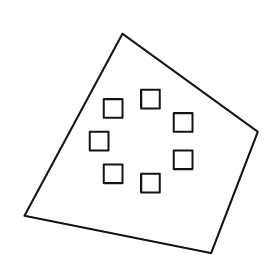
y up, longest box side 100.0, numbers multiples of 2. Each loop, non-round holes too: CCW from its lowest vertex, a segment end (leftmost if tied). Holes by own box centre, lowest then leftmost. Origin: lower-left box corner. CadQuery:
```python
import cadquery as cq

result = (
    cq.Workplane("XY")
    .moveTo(80.0, 0.0)
    .lineTo(100.0, 52.0)
    .lineTo(42.0, 94.0)
    .lineTo(0.0, 16.0)
    .close()
    .moveTo(50.0, 26.0)
    .lineTo(58.0, 26.0)
    .lineTo(58.0, 34.0)
    .lineTo(50.0, 34.0)
    .close()
    .moveTo(34.0, 30.0)
    .lineTo(42.0, 30.0)
    .lineTo(42.0, 38.0)
    .lineTo(34.0, 38.0)
    .close()
    .moveTo(64.0, 36.0)
    .lineTo(72.0, 36.0)
    .lineTo(72.0, 44.0)
    .lineTo(64.0, 44.0)
    .close()
    .moveTo(28.0, 44.0)
    .lineTo(36.0, 44.0)
    .lineTo(36.0, 52.0)
    .lineTo(28.0, 52.0)
    .close()
    .moveTo(64.0, 52.0)
    .lineTo(72.0, 52.0)
    .lineTo(72.0, 60.0)
    .lineTo(64.0, 60.0)
    .close()
    .moveTo(34.0, 58.0)
    .lineTo(42.0, 58.0)
    .lineTo(42.0, 66.0)
    .lineTo(34.0, 66.0)
    .close()
    .moveTo(50.0, 62.0)
    .lineTo(58.0, 62.0)
    .lineTo(58.0, 70.0)
    .lineTo(50.0, 70.0)
    .close()
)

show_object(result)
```